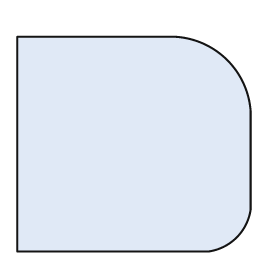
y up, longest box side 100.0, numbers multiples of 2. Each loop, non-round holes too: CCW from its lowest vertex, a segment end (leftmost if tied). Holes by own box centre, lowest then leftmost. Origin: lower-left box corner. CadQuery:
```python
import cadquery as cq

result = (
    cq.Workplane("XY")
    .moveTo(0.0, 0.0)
    .lineTo(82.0, 0.0)
    .threePointArc((94.0, 6.0), (100.0, 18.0))
    .lineTo(100.0, 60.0)
    .threePointArc((90.0, 82.0), (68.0, 92.0))
    .lineTo(0.0, 92.0)
    .close()
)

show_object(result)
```